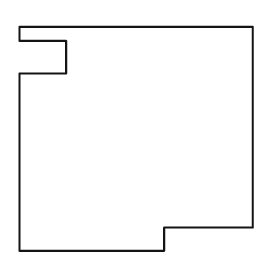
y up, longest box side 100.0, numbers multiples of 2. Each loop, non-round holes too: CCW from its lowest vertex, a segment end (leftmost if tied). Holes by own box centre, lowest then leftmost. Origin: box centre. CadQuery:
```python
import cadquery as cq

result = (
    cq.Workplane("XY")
    .moveTo(-50.0, -48.0)
    .lineTo(12.0, -48.0)
    .lineTo(12.0, -38.0)
    .lineTo(50.0, -38.0)
    .lineTo(50.0, 48.0)
    .lineTo(-50.0, 48.0)
    .lineTo(-50.0, 42.0)
    .lineTo(-30.0, 42.0)
    .lineTo(-30.0, 28.0)
    .lineTo(-50.0, 28.0)
    .close()
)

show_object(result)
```